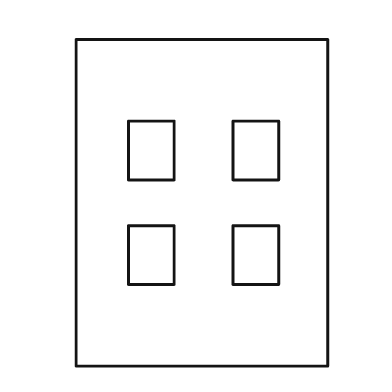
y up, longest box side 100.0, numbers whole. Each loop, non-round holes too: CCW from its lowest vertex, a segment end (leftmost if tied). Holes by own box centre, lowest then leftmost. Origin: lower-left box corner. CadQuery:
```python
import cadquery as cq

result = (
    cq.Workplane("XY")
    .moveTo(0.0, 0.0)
    .lineTo(77.0, 0.0)
    .lineTo(77.0, 100.0)
    .lineTo(0.0, 100.0)
    .close()
    .moveTo(16.0, 25.0)
    .lineTo(30.0, 25.0)
    .lineTo(30.0, 43.0)
    .lineTo(16.0, 43.0)
    .close()
    .moveTo(48.0, 25.0)
    .lineTo(62.0, 25.0)
    .lineTo(62.0, 43.0)
    .lineTo(48.0, 43.0)
    .close()
    .moveTo(16.0, 57.0)
    .lineTo(30.0, 57.0)
    .lineTo(30.0, 75.0)
    .lineTo(16.0, 75.0)
    .close()
    .moveTo(48.0, 57.0)
    .lineTo(62.0, 57.0)
    .lineTo(62.0, 75.0)
    .lineTo(48.0, 75.0)
    .close()
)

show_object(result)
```